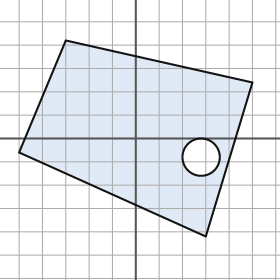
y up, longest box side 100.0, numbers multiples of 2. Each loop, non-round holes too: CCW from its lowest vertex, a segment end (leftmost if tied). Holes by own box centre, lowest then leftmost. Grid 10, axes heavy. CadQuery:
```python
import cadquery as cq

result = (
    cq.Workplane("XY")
    .moveTo(30.0, -42.0)
    .lineTo(50.0, 24.0)
    .lineTo(-30.0, 42.0)
    .lineTo(-50.0, -6.0)
    .close()
    .moveTo(28.0, -8.0)
    .circle(8.0)
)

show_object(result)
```